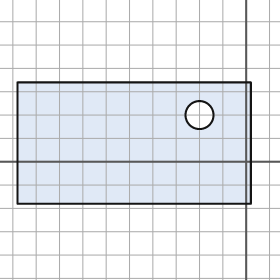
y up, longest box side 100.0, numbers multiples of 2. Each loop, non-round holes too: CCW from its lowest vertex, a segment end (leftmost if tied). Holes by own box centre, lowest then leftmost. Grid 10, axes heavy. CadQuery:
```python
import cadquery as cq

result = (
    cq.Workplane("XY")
    .moveTo(-98.0, -18.0)
    .lineTo(2.0, -18.0)
    .lineTo(2.0, 34.0)
    .lineTo(-98.0, 34.0)
    .close()
    .moveTo(-20.0, 20.0)
    .circle(6.0)
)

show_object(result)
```